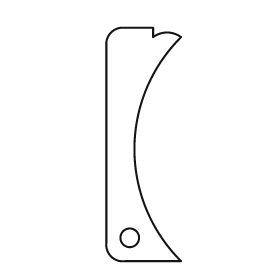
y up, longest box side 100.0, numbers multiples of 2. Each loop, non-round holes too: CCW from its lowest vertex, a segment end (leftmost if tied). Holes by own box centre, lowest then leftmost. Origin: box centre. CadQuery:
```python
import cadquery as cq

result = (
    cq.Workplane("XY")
    .moveTo(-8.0, -50.0)
    .lineTo(16.0, -50.0)
    .threePointArc((-4.0, -2.0), (16.0, 46.0))
    .threePointArc((10.0, 48.0), (4.0, 46.0))
    .lineTo(4.0, 50.0)
    .lineTo(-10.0, 50.0)
    .threePointArc((-14.0, 48.0), (-16.0, 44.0))
    .lineTo(-16.0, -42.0)
    .threePointArc((-14.0, -48.0), (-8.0, -50.0))
    .close()
    .moveTo(-6.0, -40.0)
    .circle(4.0)
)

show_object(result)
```